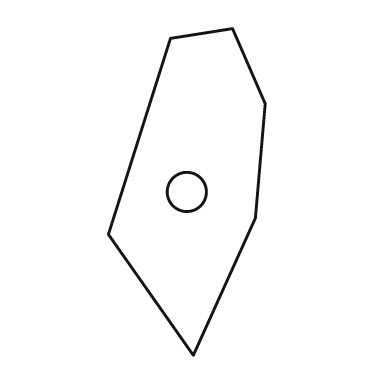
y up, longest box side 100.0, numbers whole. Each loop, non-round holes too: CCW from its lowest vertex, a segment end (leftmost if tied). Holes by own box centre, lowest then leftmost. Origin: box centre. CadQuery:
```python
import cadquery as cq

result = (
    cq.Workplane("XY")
    .moveTo(2.0, -50.0)
    .lineTo(21.0, -8.0)
    .lineTo(24.0, 27.0)
    .lineTo(14.0, 50.0)
    .lineTo(-5.0, 47.0)
    .lineTo(-24.0, -13.0)
    .close()
    .moveTo(0.0, 0.0)
    .circle(6.0)
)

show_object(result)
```